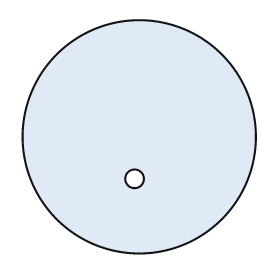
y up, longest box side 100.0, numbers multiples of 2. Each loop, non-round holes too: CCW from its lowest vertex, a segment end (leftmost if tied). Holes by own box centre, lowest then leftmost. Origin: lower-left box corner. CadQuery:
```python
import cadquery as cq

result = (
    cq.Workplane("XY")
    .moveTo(50.0, 50.0)
    .circle(50.0)
    .moveTo(48.0, 32.0)
    .circle(4.0)
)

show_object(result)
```